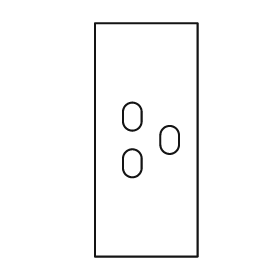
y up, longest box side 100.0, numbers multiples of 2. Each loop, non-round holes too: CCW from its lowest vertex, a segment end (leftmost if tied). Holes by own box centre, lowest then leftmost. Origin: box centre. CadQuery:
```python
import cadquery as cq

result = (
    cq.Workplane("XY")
    .moveTo(-22.0, -50.0)
    .lineTo(22.0, -50.0)
    .lineTo(22.0, 50.0)
    .lineTo(-22.0, 50.0)
    .close()
    .moveTo(-10.0, -12.0)
    .threePointArc((-6.0, -16.0), (-2.0, -12.0))
    .lineTo(-2.0, -8.0)
    .threePointArc((-6.0, -4.0), (-10.0, -8.0))
    .close()
    .moveTo(6.0, -2.0)
    .threePointArc((10.0, -6.0), (14.0, -2.0))
    .lineTo(14.0, 2.0)
    .threePointArc((10.0, 6.0), (6.0, 2.0))
    .close()
    .moveTo(-10.0, 8.0)
    .threePointArc((-6.0, 4.0), (-2.0, 8.0))
    .lineTo(-2.0, 12.0)
    .threePointArc((-6.0, 16.0), (-10.0, 12.0))
    .close()
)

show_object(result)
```